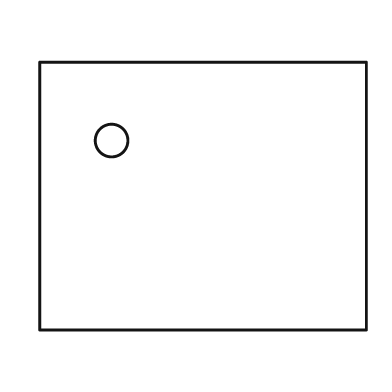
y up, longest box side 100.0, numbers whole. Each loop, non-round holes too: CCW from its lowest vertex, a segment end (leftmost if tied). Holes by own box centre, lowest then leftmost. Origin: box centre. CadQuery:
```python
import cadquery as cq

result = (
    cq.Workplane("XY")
    .moveTo(-50.0, -41.0)
    .lineTo(50.0, -41.0)
    .lineTo(50.0, 41.0)
    .lineTo(-50.0, 41.0)
    .close()
    .moveTo(-28.0, 17.0)
    .circle(5.0)
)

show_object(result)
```